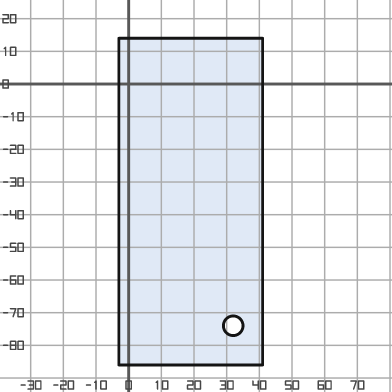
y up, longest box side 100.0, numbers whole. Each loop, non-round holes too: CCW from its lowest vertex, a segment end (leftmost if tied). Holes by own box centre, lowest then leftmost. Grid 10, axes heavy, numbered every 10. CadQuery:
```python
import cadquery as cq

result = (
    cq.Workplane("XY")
    .moveTo(-3.0, -86.0)
    .lineTo(41.0, -86.0)
    .lineTo(41.0, 14.0)
    .lineTo(-3.0, 14.0)
    .close()
    .moveTo(32.0, -74.0)
    .circle(3.0)
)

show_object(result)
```